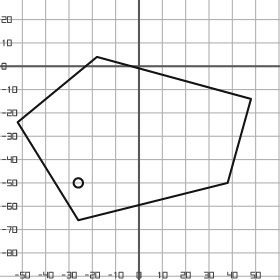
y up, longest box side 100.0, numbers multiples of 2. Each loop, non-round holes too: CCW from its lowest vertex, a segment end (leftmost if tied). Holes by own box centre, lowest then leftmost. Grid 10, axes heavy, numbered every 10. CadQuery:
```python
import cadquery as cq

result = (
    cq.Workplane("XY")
    .moveTo(-26.0, -66.0)
    .lineTo(38.0, -50.0)
    .lineTo(48.0, -14.0)
    .lineTo(-18.0, 4.0)
    .lineTo(-52.0, -24.0)
    .close()
    .moveTo(-26.0, -50.0)
    .circle(2.0)
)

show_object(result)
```